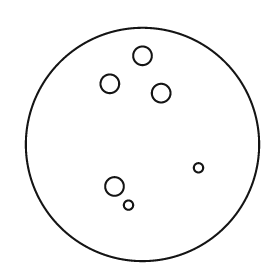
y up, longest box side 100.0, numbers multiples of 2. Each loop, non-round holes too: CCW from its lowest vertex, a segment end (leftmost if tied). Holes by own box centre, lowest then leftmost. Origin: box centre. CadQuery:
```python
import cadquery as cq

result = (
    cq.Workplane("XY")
    .moveTo(0.0, 0.0)
    .circle(50.0)
    .moveTo(-6.0, -26.0)
    .circle(2.0)
    .moveTo(-12.0, -18.0)
    .circle(4.0)
    .moveTo(24.0, -10.0)
    .circle(2.0)
    .moveTo(8.0, 22.0)
    .circle(4.0)
    .moveTo(-14.0, 26.0)
    .circle(4.0)
    .moveTo(0.0, 38.0)
    .circle(4.0)
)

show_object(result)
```